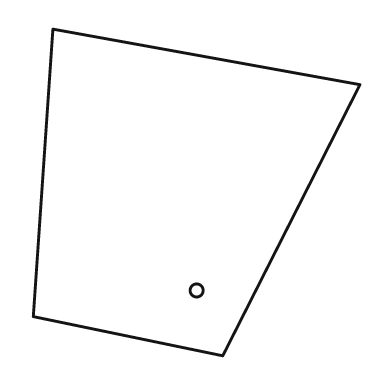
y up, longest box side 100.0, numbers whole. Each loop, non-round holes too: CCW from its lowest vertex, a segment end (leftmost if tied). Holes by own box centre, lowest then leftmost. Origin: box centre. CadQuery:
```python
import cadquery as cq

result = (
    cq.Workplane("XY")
    .moveTo(8.0, -50.0)
    .lineTo(50.0, 33.0)
    .lineTo(-44.0, 50.0)
    .lineTo(-50.0, -38.0)
    .close()
    .moveTo(0.0, -30.0)
    .circle(2.0)
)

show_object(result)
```